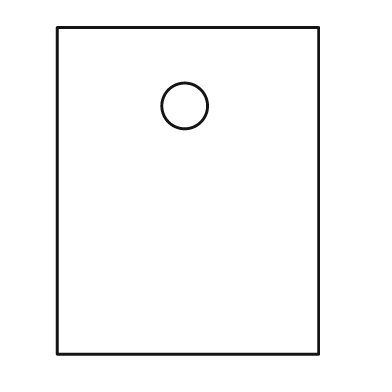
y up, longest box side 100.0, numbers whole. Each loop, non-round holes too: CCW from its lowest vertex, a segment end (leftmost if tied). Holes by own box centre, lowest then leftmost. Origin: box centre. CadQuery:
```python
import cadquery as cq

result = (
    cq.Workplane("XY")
    .moveTo(-40.0, -50.0)
    .lineTo(40.0, -50.0)
    .lineTo(40.0, 50.0)
    .lineTo(-40.0, 50.0)
    .close()
    .moveTo(-1.0, 26.0)
    .circle(7.0)
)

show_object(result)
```